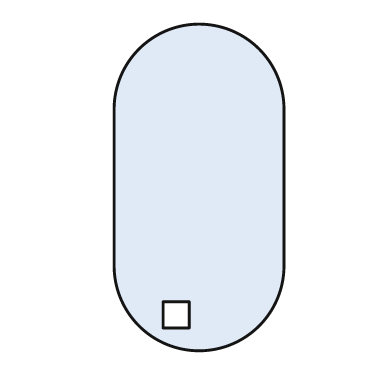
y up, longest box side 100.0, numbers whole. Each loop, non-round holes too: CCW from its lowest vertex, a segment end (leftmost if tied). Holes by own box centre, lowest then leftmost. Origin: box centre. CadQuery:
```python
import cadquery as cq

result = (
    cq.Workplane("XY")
    .moveTo(-26.0, -24.0)
    .threePointArc((0.0, -50.0), (26.0, -24.0))
    .lineTo(26.0, 24.0)
    .threePointArc((0.0, 50.0), (-26.0, 24.0))
    .close()
    .moveTo(-11.0, -43.0)
    .lineTo(-3.0, -43.0)
    .lineTo(-3.0, -35.0)
    .lineTo(-11.0, -35.0)
    .close()
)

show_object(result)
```